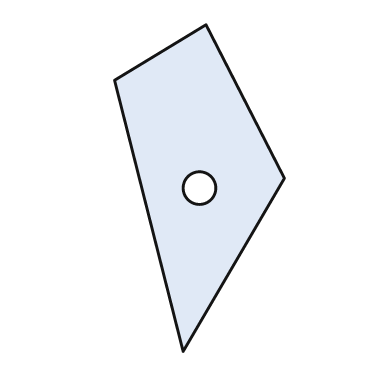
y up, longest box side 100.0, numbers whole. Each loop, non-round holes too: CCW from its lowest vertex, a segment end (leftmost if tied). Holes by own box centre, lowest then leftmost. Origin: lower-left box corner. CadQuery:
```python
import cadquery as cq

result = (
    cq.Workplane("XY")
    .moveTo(21.0, 0.0)
    .lineTo(52.0, 53.0)
    .lineTo(28.0, 100.0)
    .lineTo(0.0, 83.0)
    .close()
    .moveTo(26.0, 50.0)
    .circle(5.0)
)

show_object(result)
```